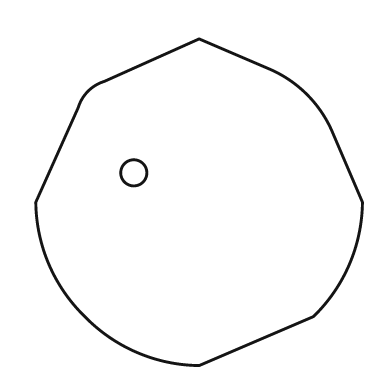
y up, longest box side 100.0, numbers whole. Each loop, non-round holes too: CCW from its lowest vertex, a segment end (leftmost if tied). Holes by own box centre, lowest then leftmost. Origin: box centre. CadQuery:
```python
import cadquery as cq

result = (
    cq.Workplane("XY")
    .moveTo(0.0, -50.0)
    .lineTo(35.0, -35.0)
    .threePointArc((46.0, -19.0), (50.0, 0.0))
    .lineTo(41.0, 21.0)
    .threePointArc((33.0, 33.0), (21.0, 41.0))
    .lineTo(0.0, 50.0)
    .lineTo(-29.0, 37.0)
    .threePointArc((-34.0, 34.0), (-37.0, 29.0))
    .lineTo(-50.0, 0.0)
    .threePointArc((-46.0, -19.0), (-35.0, -35.0))
    .threePointArc((-19.0, -46.0), (0.0, -50.0))
    .close()
    .moveTo(-20.0, 9.0)
    .circle(4.0)
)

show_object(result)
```